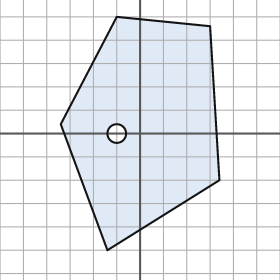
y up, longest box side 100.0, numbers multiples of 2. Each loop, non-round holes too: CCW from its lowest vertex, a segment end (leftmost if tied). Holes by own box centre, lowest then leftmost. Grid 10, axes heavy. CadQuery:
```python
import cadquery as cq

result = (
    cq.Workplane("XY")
    .moveTo(-14.0, -50.0)
    .lineTo(34.0, -20.0)
    .lineTo(30.0, 46.0)
    .lineTo(-10.0, 50.0)
    .lineTo(-34.0, 4.0)
    .close()
    .moveTo(-10.0, 0.0)
    .circle(4.0)
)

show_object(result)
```